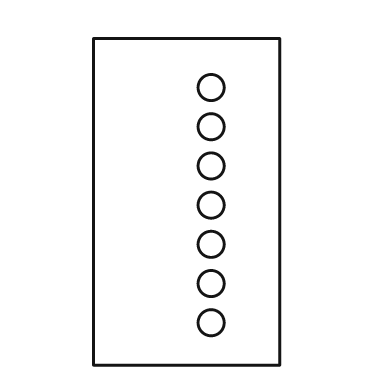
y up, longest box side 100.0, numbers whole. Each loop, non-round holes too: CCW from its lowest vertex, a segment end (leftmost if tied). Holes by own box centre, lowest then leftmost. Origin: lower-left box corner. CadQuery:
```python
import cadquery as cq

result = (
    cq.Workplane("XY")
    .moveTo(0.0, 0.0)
    .lineTo(57.0, 0.0)
    .lineTo(57.0, 100.0)
    .lineTo(0.0, 100.0)
    .close()
    .moveTo(36.0, 13.0)
    .circle(4.0)
    .moveTo(36.0, 25.0)
    .circle(4.0)
    .moveTo(36.0, 37.0)
    .circle(4.0)
    .moveTo(36.0, 49.0)
    .circle(4.0)
    .moveTo(36.0, 61.0)
    .circle(4.0)
    .moveTo(36.0, 73.0)
    .circle(4.0)
    .moveTo(36.0, 85.0)
    .circle(4.0)
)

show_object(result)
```